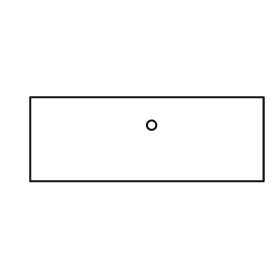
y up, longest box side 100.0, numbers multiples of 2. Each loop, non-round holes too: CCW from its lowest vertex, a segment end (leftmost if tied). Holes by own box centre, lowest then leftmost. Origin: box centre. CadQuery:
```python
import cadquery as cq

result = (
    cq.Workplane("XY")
    .moveTo(-50.0, -18.0)
    .lineTo(50.0, -18.0)
    .lineTo(50.0, 18.0)
    .lineTo(-50.0, 18.0)
    .close()
    .moveTo(2.0, 6.0)
    .circle(2.0)
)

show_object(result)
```